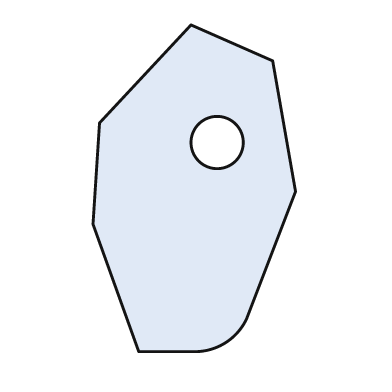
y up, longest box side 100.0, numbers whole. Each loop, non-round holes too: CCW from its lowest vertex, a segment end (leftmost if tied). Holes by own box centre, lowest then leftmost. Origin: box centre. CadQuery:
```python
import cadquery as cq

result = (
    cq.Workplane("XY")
    .moveTo(-17.0, -50.0)
    .lineTo(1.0, -50.0)
    .threePointArc((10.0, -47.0), (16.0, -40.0))
    .lineTo(31.0, -1.0)
    .lineTo(24.0, 39.0)
    .lineTo(-1.0, 50.0)
    .lineTo(-29.0, 20.0)
    .lineTo(-31.0, -11.0)
    .close()
    .moveTo(7.0, 14.0)
    .circle(8.0)
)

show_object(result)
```